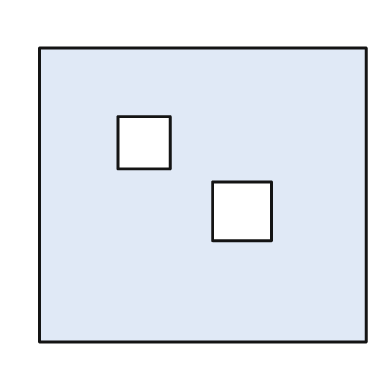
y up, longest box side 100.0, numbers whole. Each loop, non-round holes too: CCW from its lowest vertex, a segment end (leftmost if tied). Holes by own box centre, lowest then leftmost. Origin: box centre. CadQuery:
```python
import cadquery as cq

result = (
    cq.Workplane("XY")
    .moveTo(-50.0, -45.0)
    .lineTo(50.0, -45.0)
    .lineTo(50.0, 45.0)
    .lineTo(-50.0, 45.0)
    .close()
    .moveTo(3.0, -14.0)
    .lineTo(21.0, -14.0)
    .lineTo(21.0, 4.0)
    .lineTo(3.0, 4.0)
    .close()
    .moveTo(-26.0, 8.0)
    .lineTo(-10.0, 8.0)
    .lineTo(-10.0, 24.0)
    .lineTo(-26.0, 24.0)
    .close()
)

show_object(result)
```